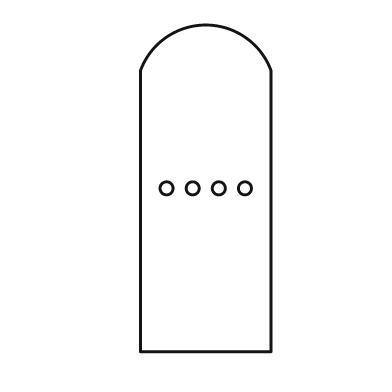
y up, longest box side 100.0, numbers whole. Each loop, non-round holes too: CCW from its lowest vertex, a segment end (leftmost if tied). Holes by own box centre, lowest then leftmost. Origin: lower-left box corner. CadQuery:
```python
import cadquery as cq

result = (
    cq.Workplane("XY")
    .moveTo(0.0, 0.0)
    .lineTo(40.0, 0.0)
    .lineTo(40.0, 86.0)
    .threePointArc((20.0, 100.0), (0.0, 86.0))
    .close()
    .moveTo(8.0, 50.0)
    .circle(2.0)
    .moveTo(16.0, 50.0)
    .circle(2.0)
    .moveTo(24.0, 50.0)
    .circle(2.0)
    .moveTo(32.0, 50.0)
    .circle(2.0)
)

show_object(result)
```